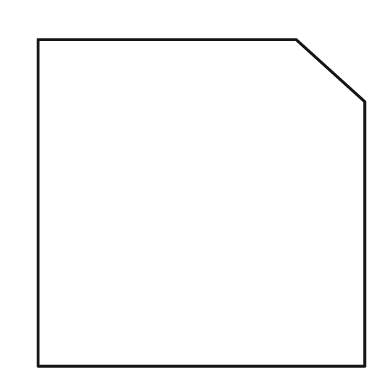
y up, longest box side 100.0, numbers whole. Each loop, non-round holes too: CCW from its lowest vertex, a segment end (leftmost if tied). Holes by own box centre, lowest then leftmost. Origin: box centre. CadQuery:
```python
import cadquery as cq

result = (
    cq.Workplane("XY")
    .moveTo(-50.0, -50.0)
    .lineTo(50.0, -50.0)
    .lineTo(50.0, 31.0)
    .lineTo(29.0, 50.0)
    .lineTo(-50.0, 50.0)
    .close()
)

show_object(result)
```